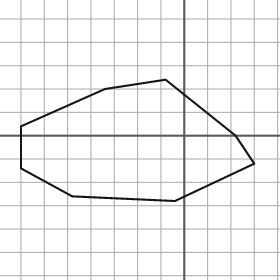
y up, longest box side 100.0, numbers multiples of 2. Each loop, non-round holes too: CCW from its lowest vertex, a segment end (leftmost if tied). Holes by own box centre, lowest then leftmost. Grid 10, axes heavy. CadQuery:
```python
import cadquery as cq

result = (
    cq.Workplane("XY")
    .moveTo(-4.0, -28.0)
    .lineTo(30.0, -12.0)
    .lineTo(22.0, 0.0)
    .lineTo(-8.0, 24.0)
    .lineTo(-34.0, 20.0)
    .lineTo(-70.0, 4.0)
    .lineTo(-70.0, -14.0)
    .lineTo(-48.0, -26.0)
    .close()
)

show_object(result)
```